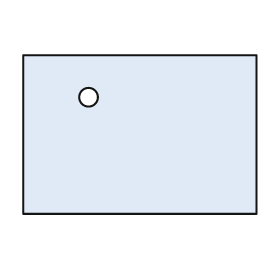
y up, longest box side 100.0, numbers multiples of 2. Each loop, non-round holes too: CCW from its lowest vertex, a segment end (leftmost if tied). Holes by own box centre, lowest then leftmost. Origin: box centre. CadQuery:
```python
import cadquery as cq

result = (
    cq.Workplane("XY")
    .moveTo(-50.0, -34.0)
    .lineTo(50.0, -34.0)
    .lineTo(50.0, 34.0)
    .lineTo(-50.0, 34.0)
    .close()
    .moveTo(-22.0, 16.0)
    .circle(4.0)
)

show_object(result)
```